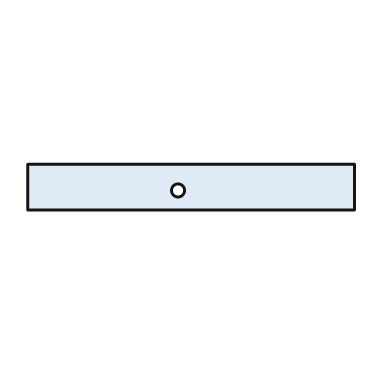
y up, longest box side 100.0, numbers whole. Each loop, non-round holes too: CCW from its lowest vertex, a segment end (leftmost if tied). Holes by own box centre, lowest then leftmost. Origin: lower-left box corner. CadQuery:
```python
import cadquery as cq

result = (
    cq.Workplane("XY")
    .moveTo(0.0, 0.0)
    .lineTo(100.0, 0.0)
    .lineTo(100.0, 14.0)
    .lineTo(0.0, 14.0)
    .close()
    .moveTo(46.0, 6.0)
    .circle(2.0)
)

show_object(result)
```